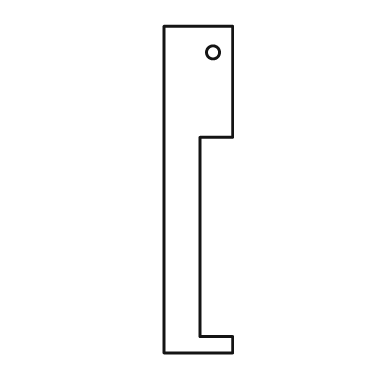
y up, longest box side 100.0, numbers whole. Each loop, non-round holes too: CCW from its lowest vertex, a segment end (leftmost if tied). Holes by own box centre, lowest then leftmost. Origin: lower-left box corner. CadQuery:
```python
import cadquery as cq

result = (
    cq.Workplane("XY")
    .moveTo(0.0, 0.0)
    .lineTo(21.0, 0.0)
    .lineTo(21.0, 5.0)
    .lineTo(11.0, 5.0)
    .lineTo(11.0, 66.0)
    .lineTo(21.0, 66.0)
    .lineTo(21.0, 100.0)
    .lineTo(0.0, 100.0)
    .close()
    .moveTo(15.0, 92.0)
    .circle(2.0)
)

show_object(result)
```